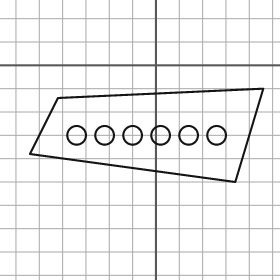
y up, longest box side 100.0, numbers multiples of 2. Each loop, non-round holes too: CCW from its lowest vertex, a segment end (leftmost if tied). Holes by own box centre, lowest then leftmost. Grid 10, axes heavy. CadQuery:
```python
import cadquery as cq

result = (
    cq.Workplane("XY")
    .moveTo(34.0, -50.0)
    .lineTo(46.0, -10.0)
    .lineTo(-42.0, -14.0)
    .lineTo(-54.0, -38.0)
    .close()
    .moveTo(-34.0, -30.0)
    .circle(4.0)
    .moveTo(-22.0, -30.0)
    .circle(4.0)
    .moveTo(-10.0, -30.0)
    .circle(4.0)
    .moveTo(2.0, -30.0)
    .circle(4.0)
    .moveTo(14.0, -30.0)
    .circle(4.0)
    .moveTo(26.0, -30.0)
    .circle(4.0)
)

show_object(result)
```